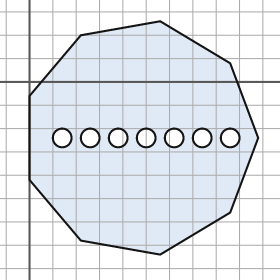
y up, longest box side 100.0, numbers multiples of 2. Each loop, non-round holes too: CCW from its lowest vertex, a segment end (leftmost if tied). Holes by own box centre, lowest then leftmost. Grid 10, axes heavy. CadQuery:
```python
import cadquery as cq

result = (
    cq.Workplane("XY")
    .moveTo(56.0, -74.0)
    .lineTo(86.0, -56.0)
    .lineTo(98.0, -24.0)
    .lineTo(86.0, 8.0)
    .lineTo(56.0, 26.0)
    .lineTo(22.0, 20.0)
    .lineTo(0.0, -6.0)
    .lineTo(0.0, -42.0)
    .lineTo(22.0, -68.0)
    .close()
    .moveTo(14.0, -24.0)
    .circle(4.0)
    .moveTo(26.0, -24.0)
    .circle(4.0)
    .moveTo(38.0, -24.0)
    .circle(4.0)
    .moveTo(50.0, -24.0)
    .circle(4.0)
    .moveTo(62.0, -24.0)
    .circle(4.0)
    .moveTo(74.0, -24.0)
    .circle(4.0)
    .moveTo(86.0, -24.0)
    .circle(4.0)
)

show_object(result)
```